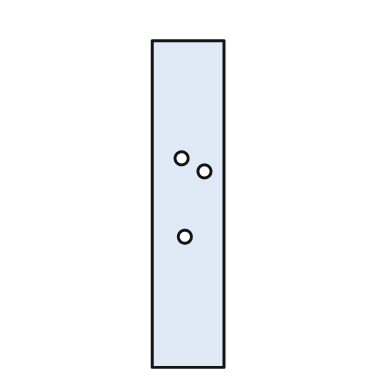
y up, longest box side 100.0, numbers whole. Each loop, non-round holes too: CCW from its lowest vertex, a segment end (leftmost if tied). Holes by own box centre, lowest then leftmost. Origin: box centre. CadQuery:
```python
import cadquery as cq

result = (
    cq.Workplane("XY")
    .moveTo(-11.0, -50.0)
    .lineTo(11.0, -50.0)
    .lineTo(11.0, 50.0)
    .lineTo(-11.0, 50.0)
    .close()
    .moveTo(-1.0, -10.0)
    .circle(2.0)
    .moveTo(5.0, 10.0)
    .circle(2.0)
    .moveTo(-2.0, 14.0)
    .circle(2.0)
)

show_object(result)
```